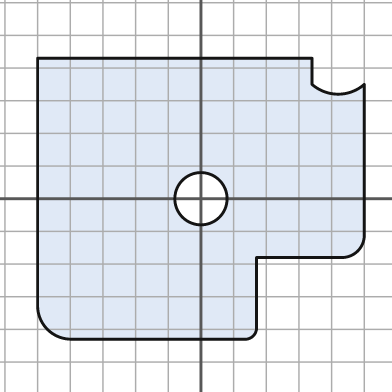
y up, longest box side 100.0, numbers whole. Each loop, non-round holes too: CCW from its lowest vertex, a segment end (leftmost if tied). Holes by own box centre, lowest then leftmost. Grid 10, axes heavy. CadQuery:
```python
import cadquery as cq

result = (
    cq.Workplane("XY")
    .moveTo(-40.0, -43.0)
    .lineTo(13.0, -43.0)
    .threePointArc((16.0, -42.0), (17.0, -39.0))
    .lineTo(17.0, -18.0)
    .lineTo(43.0, -18.0)
    .threePointArc((48.0, -16.0), (50.0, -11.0))
    .lineTo(50.0, 35.0)
    .threePointArc((42.0, 32.0), (34.0, 35.0))
    .lineTo(34.0, 43.0)
    .lineTo(-50.0, 43.0)
    .lineTo(-50.0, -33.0)
    .threePointArc((-47.0, -40.0), (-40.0, -43.0))
    .close()
    .moveTo(0.0, 0.0)
    .circle(8.0)
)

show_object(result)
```